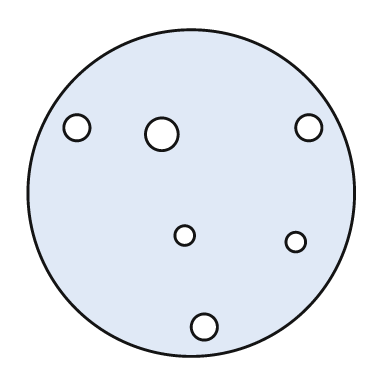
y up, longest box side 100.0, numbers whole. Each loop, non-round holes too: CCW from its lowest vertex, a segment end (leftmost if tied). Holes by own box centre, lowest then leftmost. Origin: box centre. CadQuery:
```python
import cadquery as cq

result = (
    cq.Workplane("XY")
    .moveTo(0.0, 0.0)
    .circle(50.0)
    .moveTo(4.0, -41.0)
    .circle(4.0)
    .moveTo(32.0, -15.0)
    .circle(3.0)
    .moveTo(-2.0, -13.0)
    .circle(3.0)
    .moveTo(-9.0, 18.0)
    .circle(5.0)
    .moveTo(-35.0, 20.0)
    .circle(4.0)
    .moveTo(36.0, 20.0)
    .circle(4.0)
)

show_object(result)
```